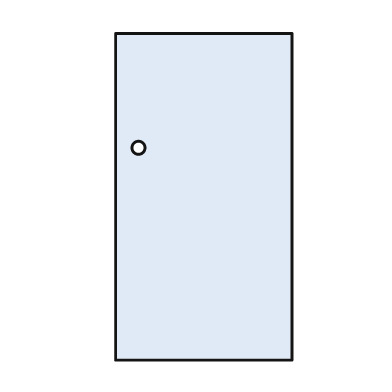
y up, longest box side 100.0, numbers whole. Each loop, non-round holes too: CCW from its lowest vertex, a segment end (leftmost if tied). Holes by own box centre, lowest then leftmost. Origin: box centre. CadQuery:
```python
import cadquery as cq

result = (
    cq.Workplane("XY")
    .moveTo(-27.0, -50.0)
    .lineTo(27.0, -50.0)
    .lineTo(27.0, 50.0)
    .lineTo(-27.0, 50.0)
    .close()
    .moveTo(-20.0, 15.0)
    .circle(2.0)
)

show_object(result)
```